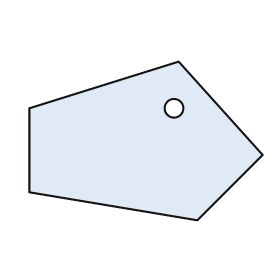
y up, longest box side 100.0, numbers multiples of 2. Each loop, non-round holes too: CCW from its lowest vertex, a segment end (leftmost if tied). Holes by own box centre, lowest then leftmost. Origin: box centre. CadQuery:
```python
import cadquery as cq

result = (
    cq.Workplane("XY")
    .moveTo(22.0, -34.0)
    .lineTo(50.0, -6.0)
    .lineTo(14.0, 34.0)
    .lineTo(-50.0, 14.0)
    .lineTo(-50.0, -22.0)
    .close()
    .moveTo(12.0, 14.0)
    .circle(4.0)
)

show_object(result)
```